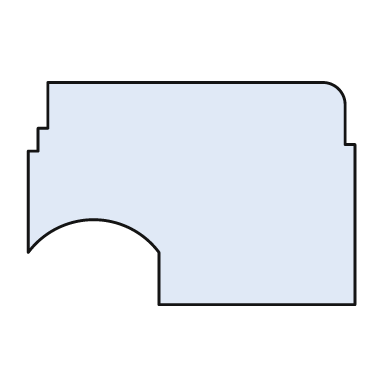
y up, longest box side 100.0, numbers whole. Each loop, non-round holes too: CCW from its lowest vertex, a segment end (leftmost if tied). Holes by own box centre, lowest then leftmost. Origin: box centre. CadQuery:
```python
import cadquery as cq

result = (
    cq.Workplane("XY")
    .moveTo(-10.0, -34.0)
    .lineTo(50.0, -34.0)
    .lineTo(50.0, 15.0)
    .lineTo(47.0, 15.0)
    .lineTo(47.0, 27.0)
    .threePointArc((45.0, 32.0), (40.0, 34.0))
    .lineTo(-44.0, 34.0)
    .lineTo(-44.0, 20.0)
    .lineTo(-47.0, 20.0)
    .lineTo(-47.0, 13.0)
    .lineTo(-50.0, 13.0)
    .lineTo(-50.0, -18.0)
    .threePointArc((-30.0, -8.0), (-10.0, -18.0))
    .close()
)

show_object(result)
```